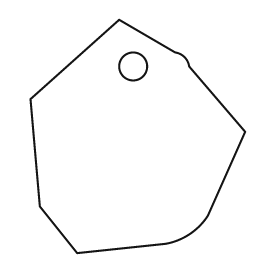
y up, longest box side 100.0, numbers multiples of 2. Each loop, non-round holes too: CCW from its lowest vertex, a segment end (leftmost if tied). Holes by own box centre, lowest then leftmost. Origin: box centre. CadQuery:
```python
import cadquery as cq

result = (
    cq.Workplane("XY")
    .moveTo(-26.0, -50.0)
    .lineTo(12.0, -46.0)
    .threePointArc((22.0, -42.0), (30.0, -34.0))
    .lineTo(46.0, 2.0)
    .lineTo(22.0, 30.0)
    .threePointArc((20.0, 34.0), (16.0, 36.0))
    .lineTo(-8.0, 50.0)
    .lineTo(-46.0, 16.0)
    .lineTo(-42.0, -30.0)
    .close()
    .moveTo(-2.0, 30.0)
    .circle(6.0)
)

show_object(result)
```